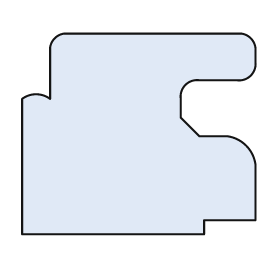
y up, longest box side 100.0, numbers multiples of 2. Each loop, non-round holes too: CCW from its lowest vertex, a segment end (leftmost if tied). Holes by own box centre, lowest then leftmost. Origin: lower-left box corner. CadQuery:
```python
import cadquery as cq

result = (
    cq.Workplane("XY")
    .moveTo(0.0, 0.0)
    .lineTo(78.0, 0.0)
    .lineTo(78.0, 6.0)
    .lineTo(100.0, 6.0)
    .lineTo(100.0, 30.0)
    .threePointArc((96.0, 38.0), (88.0, 42.0))
    .lineTo(76.0, 42.0)
    .lineTo(68.0, 50.0)
    .lineTo(68.0, 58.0)
    .threePointArc((70.0, 64.0), (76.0, 66.0))
    .lineTo(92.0, 66.0)
    .threePointArc((98.0, 68.0), (100.0, 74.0))
    .lineTo(100.0, 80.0)
    .threePointArc((98.0, 84.0), (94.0, 86.0))
    .lineTo(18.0, 86.0)
    .threePointArc((14.0, 84.0), (12.0, 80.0))
    .lineTo(12.0, 58.0)
    .threePointArc((6.0, 60.0), (0.0, 58.0))
    .close()
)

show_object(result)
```